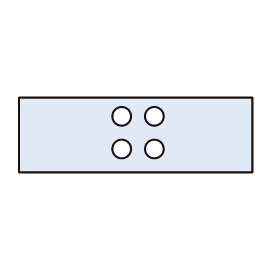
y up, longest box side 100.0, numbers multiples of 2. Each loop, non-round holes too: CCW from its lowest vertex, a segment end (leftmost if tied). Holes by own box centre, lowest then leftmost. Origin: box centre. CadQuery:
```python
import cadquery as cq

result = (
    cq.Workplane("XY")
    .moveTo(-50.0, -16.0)
    .lineTo(50.0, -16.0)
    .lineTo(50.0, 16.0)
    .lineTo(-50.0, 16.0)
    .close()
    .moveTo(-6.0, -6.0)
    .circle(4.0)
    .moveTo(8.0, -6.0)
    .circle(4.0)
    .moveTo(-6.0, 8.0)
    .circle(4.0)
    .moveTo(8.0, 8.0)
    .circle(4.0)
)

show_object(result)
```